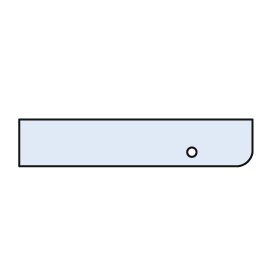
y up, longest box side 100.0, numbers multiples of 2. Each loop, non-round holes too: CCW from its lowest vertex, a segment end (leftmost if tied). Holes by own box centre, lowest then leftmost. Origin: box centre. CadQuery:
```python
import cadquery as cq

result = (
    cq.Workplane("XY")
    .moveTo(-50.0, -10.0)
    .lineTo(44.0, -10.0)
    .threePointArc((48.0, -8.0), (50.0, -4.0))
    .lineTo(50.0, 10.0)
    .lineTo(-50.0, 10.0)
    .close()
    .moveTo(24.0, -4.0)
    .circle(2.0)
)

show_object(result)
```